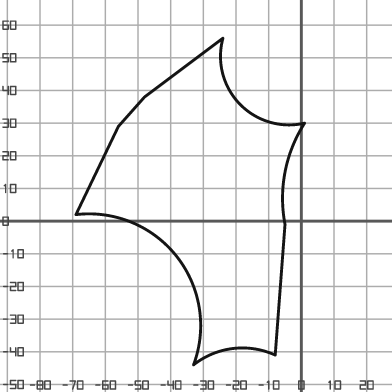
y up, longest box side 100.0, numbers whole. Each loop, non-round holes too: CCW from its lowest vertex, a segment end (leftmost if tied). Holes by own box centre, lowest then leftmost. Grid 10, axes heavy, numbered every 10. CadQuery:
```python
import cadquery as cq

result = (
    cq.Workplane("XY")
    .moveTo(-33.0, -44.0)
    .threePointArc((-21.0, -39.0), (-8.0, -41.0))
    .lineTo(-5.0, -1.0)
    .threePointArc((-5.0, 15.0), (1.0, 30.0))
    .threePointArc((-19.0, 36.0), (-24.0, 56.0))
    .lineTo(-48.0, 38.0)
    .lineTo(-56.0, 29.0)
    .lineTo(-69.0, 2.0)
    .threePointArc((-38.0, -11.0), (-33.0, -44.0))
    .close()
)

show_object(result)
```